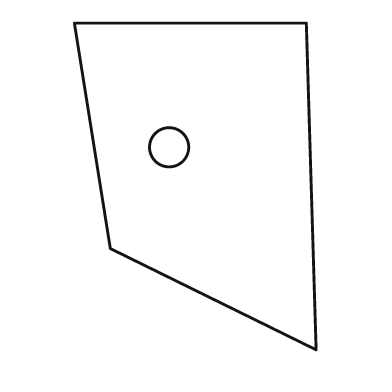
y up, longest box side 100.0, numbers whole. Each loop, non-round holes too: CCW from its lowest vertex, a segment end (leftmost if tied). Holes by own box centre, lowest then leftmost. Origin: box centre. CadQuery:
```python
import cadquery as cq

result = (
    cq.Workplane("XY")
    .moveTo(37.0, -50.0)
    .lineTo(34.0, 50.0)
    .lineTo(-37.0, 50.0)
    .lineTo(-26.0, -19.0)
    .close()
    .moveTo(-8.0, 12.0)
    .circle(6.0)
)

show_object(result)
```